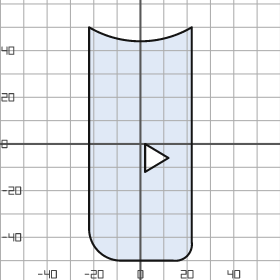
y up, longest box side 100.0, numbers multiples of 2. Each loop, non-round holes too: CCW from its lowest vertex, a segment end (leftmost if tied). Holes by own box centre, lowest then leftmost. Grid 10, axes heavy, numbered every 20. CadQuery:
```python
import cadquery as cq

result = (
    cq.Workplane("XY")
    .moveTo(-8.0, -50.0)
    .lineTo(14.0, -50.0)
    .threePointArc((20.0, -48.0), (22.0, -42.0))
    .lineTo(22.0, 50.0)
    .threePointArc((0.0, 44.0), (-22.0, 50.0))
    .lineTo(-22.0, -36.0)
    .threePointArc((-18.0, -46.0), (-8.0, -50.0))
    .close()
    .moveTo(2.0, -12.0)
    .lineTo(12.0, -6.0)
    .lineTo(2.0, 0.0)
    .close()
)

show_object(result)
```